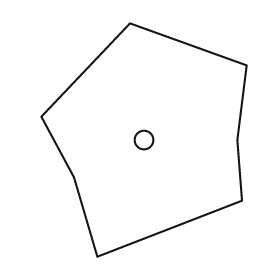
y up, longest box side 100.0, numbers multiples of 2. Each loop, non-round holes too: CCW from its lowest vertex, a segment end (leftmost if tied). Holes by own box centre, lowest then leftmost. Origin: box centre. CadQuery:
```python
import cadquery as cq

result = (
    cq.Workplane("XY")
    .moveTo(-20.0, -50.0)
    .lineTo(42.0, -26.0)
    .lineTo(40.0, 0.0)
    .lineTo(44.0, 32.0)
    .lineTo(-6.0, 50.0)
    .lineTo(-44.0, 10.0)
    .lineTo(-30.0, -16.0)
    .close()
    .moveTo(0.0, 0.0)
    .circle(4.0)
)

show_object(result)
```